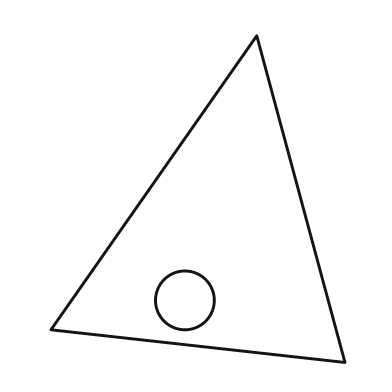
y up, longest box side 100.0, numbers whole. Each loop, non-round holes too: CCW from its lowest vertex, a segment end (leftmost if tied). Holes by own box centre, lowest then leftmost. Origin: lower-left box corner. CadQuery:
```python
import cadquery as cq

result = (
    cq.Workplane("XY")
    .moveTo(90.0, 0.0)
    .lineTo(63.0, 100.0)
    .lineTo(0.0, 10.0)
    .close()
    .moveTo(41.0, 19.0)
    .circle(9.0)
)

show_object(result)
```